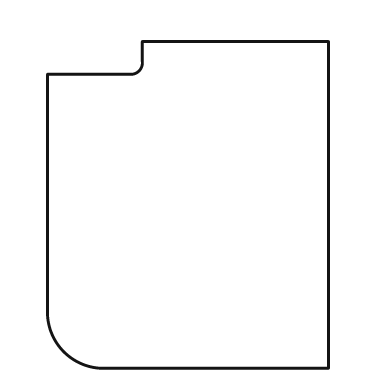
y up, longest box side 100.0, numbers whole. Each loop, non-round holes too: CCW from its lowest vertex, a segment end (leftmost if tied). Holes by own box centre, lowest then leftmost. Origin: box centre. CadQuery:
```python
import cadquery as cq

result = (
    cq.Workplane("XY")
    .moveTo(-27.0, -50.0)
    .lineTo(43.0, -50.0)
    .lineTo(43.0, 50.0)
    .lineTo(-14.0, 50.0)
    .lineTo(-14.0, 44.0)
    .threePointArc((-15.0, 41.0), (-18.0, 40.0))
    .lineTo(-43.0, 40.0)
    .lineTo(-43.0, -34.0)
    .threePointArc((-38.0, -45.0), (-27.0, -50.0))
    .close()
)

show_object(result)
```